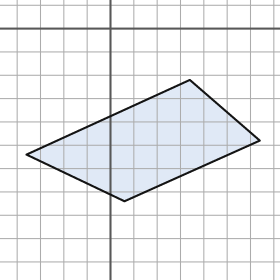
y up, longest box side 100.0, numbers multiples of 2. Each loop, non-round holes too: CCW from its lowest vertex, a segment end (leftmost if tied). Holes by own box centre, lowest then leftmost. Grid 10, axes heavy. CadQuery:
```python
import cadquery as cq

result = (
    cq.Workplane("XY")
    .moveTo(6.0, -74.0)
    .lineTo(64.0, -48.0)
    .lineTo(34.0, -22.0)
    .lineTo(-36.0, -54.0)
    .close()
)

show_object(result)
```